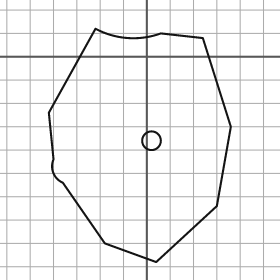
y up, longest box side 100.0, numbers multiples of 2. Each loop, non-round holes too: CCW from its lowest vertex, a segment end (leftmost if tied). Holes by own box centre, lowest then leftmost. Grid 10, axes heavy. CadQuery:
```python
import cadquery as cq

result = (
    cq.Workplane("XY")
    .moveTo(4.0, -88.0)
    .lineTo(30.0, -64.0)
    .lineTo(36.0, -30.0)
    .lineTo(24.0, 8.0)
    .lineTo(6.0, 10.0)
    .threePointArc((-8.0, 8.0), (-22.0, 12.0))
    .lineTo(-42.0, -24.0)
    .lineTo(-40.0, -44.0)
    .threePointArc((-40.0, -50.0), (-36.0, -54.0))
    .lineTo(-18.0, -80.0)
    .close()
    .moveTo(2.0, -36.0)
    .circle(4.0)
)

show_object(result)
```